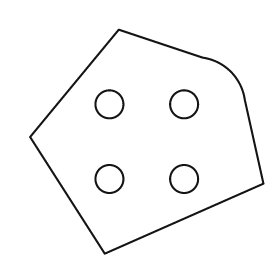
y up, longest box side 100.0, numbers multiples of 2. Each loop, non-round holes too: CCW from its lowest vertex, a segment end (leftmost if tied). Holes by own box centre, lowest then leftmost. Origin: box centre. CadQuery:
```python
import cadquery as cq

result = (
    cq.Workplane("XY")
    .moveTo(-18.0, -48.0)
    .lineTo(50.0, -18.0)
    .lineTo(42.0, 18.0)
    .threePointArc((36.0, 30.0), (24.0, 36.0))
    .lineTo(-12.0, 48.0)
    .lineTo(-50.0, 2.0)
    .close()
    .moveTo(-16.0, -16.0)
    .circle(6.0)
    .moveTo(16.0, -16.0)
    .circle(6.0)
    .moveTo(-16.0, 16.0)
    .circle(6.0)
    .moveTo(16.0, 16.0)
    .circle(6.0)
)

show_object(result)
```